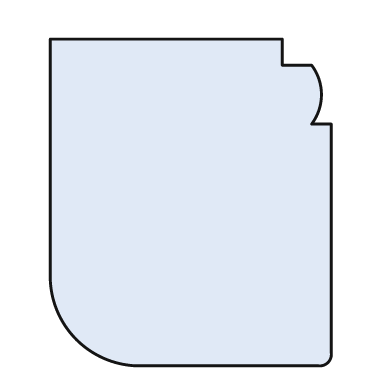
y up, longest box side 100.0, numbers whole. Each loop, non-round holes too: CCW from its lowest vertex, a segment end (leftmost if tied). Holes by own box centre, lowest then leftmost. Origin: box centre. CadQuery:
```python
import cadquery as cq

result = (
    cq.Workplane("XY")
    .moveTo(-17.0, -50.0)
    .lineTo(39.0, -50.0)
    .threePointArc((42.0, -49.0), (43.0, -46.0))
    .lineTo(43.0, 24.0)
    .lineTo(37.0, 24.0)
    .threePointArc((40.0, 33.0), (37.0, 42.0))
    .lineTo(28.0, 42.0)
    .lineTo(28.0, 50.0)
    .lineTo(-43.0, 50.0)
    .lineTo(-43.0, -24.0)
    .threePointArc((-35.0, -42.0), (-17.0, -50.0))
    .close()
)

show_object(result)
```